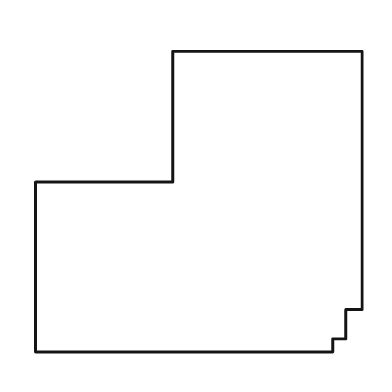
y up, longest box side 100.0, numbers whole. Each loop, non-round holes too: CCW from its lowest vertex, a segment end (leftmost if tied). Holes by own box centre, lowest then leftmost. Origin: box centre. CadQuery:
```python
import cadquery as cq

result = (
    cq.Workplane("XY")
    .moveTo(-50.0, -46.0)
    .lineTo(41.0, -46.0)
    .lineTo(41.0, -42.0)
    .lineTo(45.0, -42.0)
    .lineTo(45.0, -33.0)
    .lineTo(50.0, -33.0)
    .lineTo(50.0, 46.0)
    .lineTo(-8.0, 46.0)
    .lineTo(-8.0, 6.0)
    .lineTo(-50.0, 6.0)
    .close()
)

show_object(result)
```